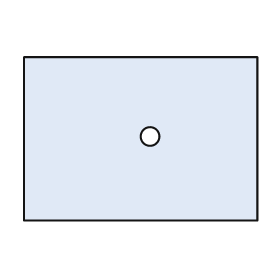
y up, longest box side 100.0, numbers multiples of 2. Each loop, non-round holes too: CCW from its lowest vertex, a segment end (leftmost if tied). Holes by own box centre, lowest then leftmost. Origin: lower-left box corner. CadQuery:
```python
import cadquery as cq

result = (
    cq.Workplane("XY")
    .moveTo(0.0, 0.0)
    .lineTo(100.0, 0.0)
    .lineTo(100.0, 70.0)
    .lineTo(0.0, 70.0)
    .close()
    .moveTo(54.0, 36.0)
    .circle(4.0)
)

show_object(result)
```